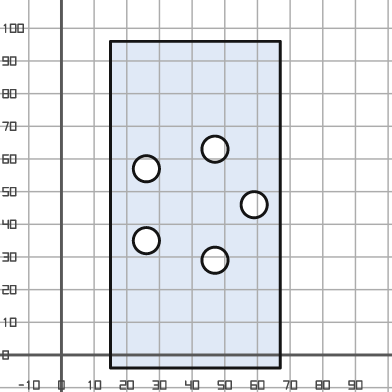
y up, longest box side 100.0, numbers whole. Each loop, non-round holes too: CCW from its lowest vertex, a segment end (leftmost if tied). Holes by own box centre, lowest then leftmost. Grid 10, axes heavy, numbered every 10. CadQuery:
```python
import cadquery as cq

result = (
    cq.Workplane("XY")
    .moveTo(15.0, -4.0)
    .lineTo(67.0, -4.0)
    .lineTo(67.0, 96.0)
    .lineTo(15.0, 96.0)
    .close()
    .moveTo(47.0, 29.0)
    .circle(4.0)
    .moveTo(26.0, 35.0)
    .circle(4.0)
    .moveTo(59.0, 46.0)
    .circle(4.0)
    .moveTo(26.0, 57.0)
    .circle(4.0)
    .moveTo(47.0, 63.0)
    .circle(4.0)
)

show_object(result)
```